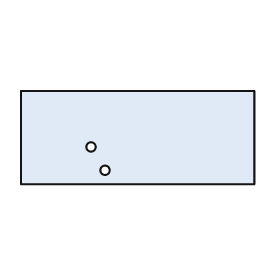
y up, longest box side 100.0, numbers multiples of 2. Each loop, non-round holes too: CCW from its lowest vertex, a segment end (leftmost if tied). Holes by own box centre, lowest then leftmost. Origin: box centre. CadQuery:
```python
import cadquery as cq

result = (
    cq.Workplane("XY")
    .moveTo(-50.0, -20.0)
    .lineTo(50.0, -20.0)
    .lineTo(50.0, 20.0)
    .lineTo(-50.0, 20.0)
    .close()
    .moveTo(-14.0, -14.0)
    .circle(2.0)
    .moveTo(-20.0, -4.0)
    .circle(2.0)
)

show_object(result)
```